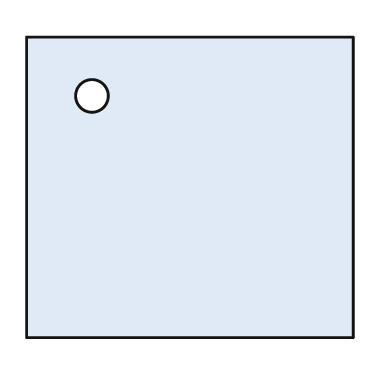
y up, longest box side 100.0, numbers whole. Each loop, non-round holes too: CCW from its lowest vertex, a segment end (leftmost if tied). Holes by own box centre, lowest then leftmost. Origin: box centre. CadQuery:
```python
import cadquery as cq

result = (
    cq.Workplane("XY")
    .moveTo(-50.0, -46.0)
    .lineTo(50.0, -46.0)
    .lineTo(50.0, 46.0)
    .lineTo(-50.0, 46.0)
    .close()
    .moveTo(-30.0, 28.0)
    .circle(5.0)
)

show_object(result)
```